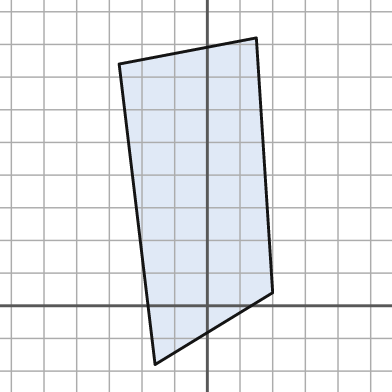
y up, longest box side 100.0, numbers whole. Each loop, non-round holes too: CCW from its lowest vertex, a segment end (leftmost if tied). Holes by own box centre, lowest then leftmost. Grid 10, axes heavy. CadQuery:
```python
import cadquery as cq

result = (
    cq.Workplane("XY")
    .moveTo(-16.0, -18.0)
    .lineTo(20.0, 4.0)
    .lineTo(15.0, 82.0)
    .lineTo(-27.0, 74.0)
    .close()
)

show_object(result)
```